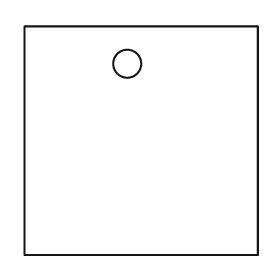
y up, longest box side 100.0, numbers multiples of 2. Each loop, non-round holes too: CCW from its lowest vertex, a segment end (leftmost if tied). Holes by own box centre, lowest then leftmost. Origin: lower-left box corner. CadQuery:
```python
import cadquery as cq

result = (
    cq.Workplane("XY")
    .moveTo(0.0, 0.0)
    .lineTo(100.0, 0.0)
    .lineTo(100.0, 98.0)
    .lineTo(0.0, 98.0)
    .close()
    .moveTo(44.0, 82.0)
    .circle(6.0)
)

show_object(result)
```